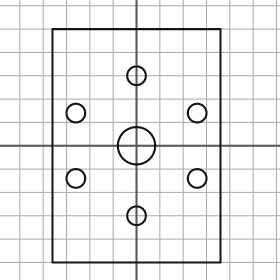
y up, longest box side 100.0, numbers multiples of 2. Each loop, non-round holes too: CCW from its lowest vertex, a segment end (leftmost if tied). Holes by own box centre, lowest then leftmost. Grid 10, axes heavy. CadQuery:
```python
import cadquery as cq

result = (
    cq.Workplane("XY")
    .moveTo(-36.0, -50.0)
    .lineTo(36.0, -50.0)
    .lineTo(36.0, 50.0)
    .lineTo(-36.0, 50.0)
    .close()
    .moveTo(0.0, -30.0)
    .circle(4.0)
    .moveTo(-26.0, -14.0)
    .circle(4.0)
    .moveTo(26.0, -14.0)
    .circle(4.0)
    .moveTo(0.0, 0.0)
    .circle(8.0)
    .moveTo(-26.0, 14.0)
    .circle(4.0)
    .moveTo(26.0, 14.0)
    .circle(4.0)
    .moveTo(0.0, 30.0)
    .circle(4.0)
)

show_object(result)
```